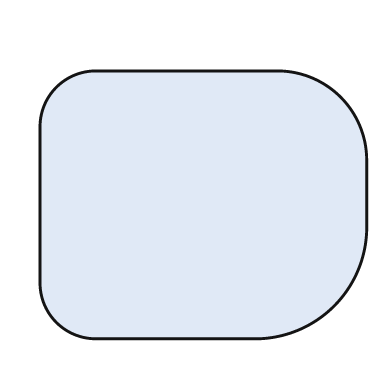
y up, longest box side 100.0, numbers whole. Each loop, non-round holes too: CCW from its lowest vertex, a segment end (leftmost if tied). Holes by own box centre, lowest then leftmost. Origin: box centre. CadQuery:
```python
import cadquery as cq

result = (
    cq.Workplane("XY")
    .moveTo(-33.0, -41.0)
    .lineTo(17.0, -41.0)
    .threePointArc((40.0, -31.0), (50.0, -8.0))
    .lineTo(50.0, 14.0)
    .threePointArc((42.0, 33.0), (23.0, 41.0))
    .lineTo(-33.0, 41.0)
    .threePointArc((-45.0, 36.0), (-50.0, 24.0))
    .lineTo(-50.0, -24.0)
    .threePointArc((-45.0, -36.0), (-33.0, -41.0))
    .close()
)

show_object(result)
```